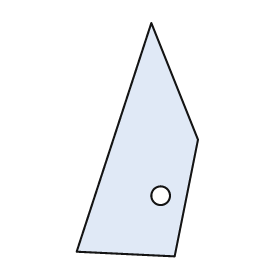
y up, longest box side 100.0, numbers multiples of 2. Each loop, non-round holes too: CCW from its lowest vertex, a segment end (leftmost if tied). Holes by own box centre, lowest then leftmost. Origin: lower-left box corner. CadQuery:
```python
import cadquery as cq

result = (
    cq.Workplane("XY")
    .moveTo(42.0, 0.0)
    .lineTo(52.0, 50.0)
    .lineTo(32.0, 100.0)
    .lineTo(0.0, 2.0)
    .close()
    .moveTo(36.0, 26.0)
    .circle(4.0)
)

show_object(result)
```